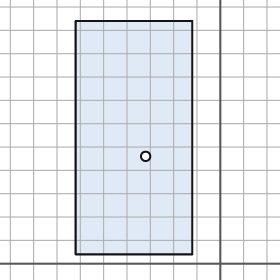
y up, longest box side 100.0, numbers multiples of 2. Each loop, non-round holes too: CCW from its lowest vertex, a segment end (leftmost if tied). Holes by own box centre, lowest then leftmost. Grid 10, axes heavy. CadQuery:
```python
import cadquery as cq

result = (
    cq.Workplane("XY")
    .moveTo(-62.0, 4.0)
    .lineTo(-12.0, 4.0)
    .lineTo(-12.0, 104.0)
    .lineTo(-62.0, 104.0)
    .close()
    .moveTo(-32.0, 46.0)
    .circle(2.0)
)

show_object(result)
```